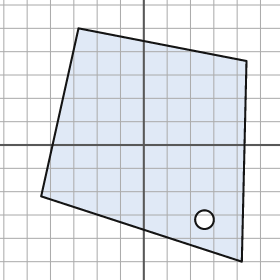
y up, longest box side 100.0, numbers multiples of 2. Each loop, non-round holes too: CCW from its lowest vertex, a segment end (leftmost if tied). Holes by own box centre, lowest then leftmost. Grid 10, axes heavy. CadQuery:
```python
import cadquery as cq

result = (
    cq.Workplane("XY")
    .moveTo(42.0, -50.0)
    .lineTo(44.0, 36.0)
    .lineTo(-28.0, 50.0)
    .lineTo(-44.0, -22.0)
    .close()
    .moveTo(26.0, -32.0)
    .circle(4.0)
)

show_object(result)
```